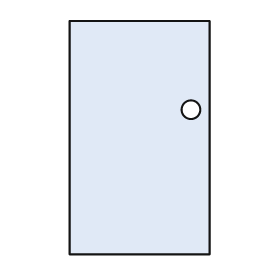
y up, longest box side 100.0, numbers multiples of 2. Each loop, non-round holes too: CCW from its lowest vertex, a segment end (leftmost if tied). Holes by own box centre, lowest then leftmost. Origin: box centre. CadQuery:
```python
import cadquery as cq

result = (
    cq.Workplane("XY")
    .moveTo(-30.0, -50.0)
    .lineTo(30.0, -50.0)
    .lineTo(30.0, 50.0)
    .lineTo(-30.0, 50.0)
    .close()
    .moveTo(22.0, 12.0)
    .circle(4.0)
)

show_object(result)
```